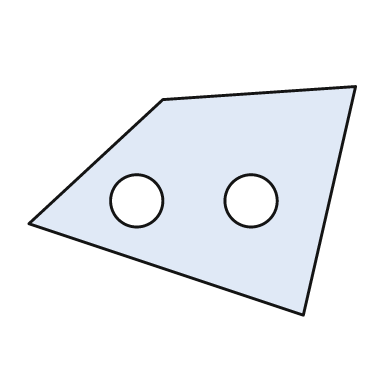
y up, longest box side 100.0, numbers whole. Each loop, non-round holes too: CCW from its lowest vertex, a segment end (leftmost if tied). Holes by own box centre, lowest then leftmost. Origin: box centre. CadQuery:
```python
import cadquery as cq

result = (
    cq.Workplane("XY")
    .moveTo(34.0, -35.0)
    .lineTo(50.0, 35.0)
    .lineTo(-9.0, 31.0)
    .lineTo(-50.0, -7.0)
    .close()
    .moveTo(-17.0, 0.0)
    .circle(8.0)
    .moveTo(18.0, 0.0)
    .circle(8.0)
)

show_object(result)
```